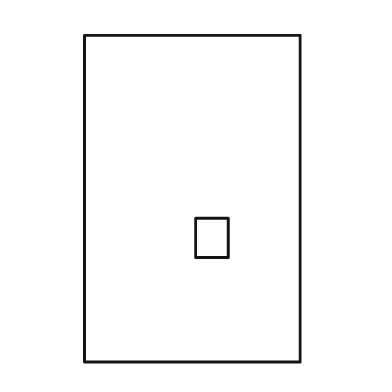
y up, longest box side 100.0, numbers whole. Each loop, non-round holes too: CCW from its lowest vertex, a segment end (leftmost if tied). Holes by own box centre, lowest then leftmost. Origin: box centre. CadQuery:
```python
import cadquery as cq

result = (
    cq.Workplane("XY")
    .moveTo(-33.0, -50.0)
    .lineTo(33.0, -50.0)
    .lineTo(33.0, 50.0)
    .lineTo(-33.0, 50.0)
    .close()
    .moveTo(1.0, -18.0)
    .lineTo(11.0, -18.0)
    .lineTo(11.0, -6.0)
    .lineTo(1.0, -6.0)
    .close()
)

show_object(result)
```